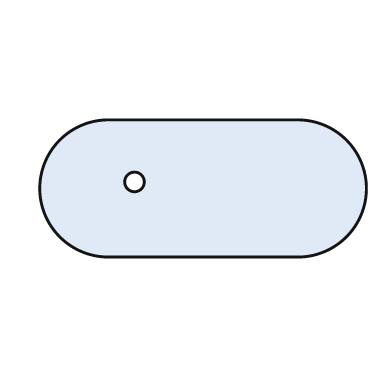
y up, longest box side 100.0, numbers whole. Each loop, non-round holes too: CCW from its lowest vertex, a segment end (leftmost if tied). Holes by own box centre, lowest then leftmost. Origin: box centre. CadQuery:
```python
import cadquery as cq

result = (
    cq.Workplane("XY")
    .moveTo(-29.0, -21.0)
    .lineTo(29.0, -21.0)
    .threePointArc((50.0, 0.0), (29.0, 21.0))
    .lineTo(-29.0, 21.0)
    .threePointArc((-50.0, 0.0), (-29.0, -21.0))
    .close()
    .moveTo(-21.0, 2.0)
    .circle(3.0)
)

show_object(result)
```